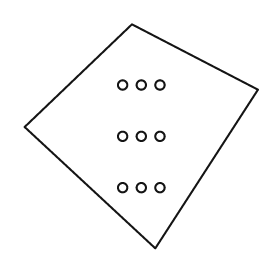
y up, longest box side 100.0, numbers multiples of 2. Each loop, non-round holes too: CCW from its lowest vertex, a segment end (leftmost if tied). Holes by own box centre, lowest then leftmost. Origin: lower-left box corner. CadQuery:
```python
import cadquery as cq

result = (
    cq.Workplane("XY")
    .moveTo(56.0, 0.0)
    .lineTo(100.0, 68.0)
    .lineTo(46.0, 96.0)
    .lineTo(0.0, 52.0)
    .close()
    .moveTo(42.0, 26.0)
    .circle(2.0)
    .moveTo(50.0, 26.0)
    .circle(2.0)
    .moveTo(58.0, 26.0)
    .circle(2.0)
    .moveTo(42.0, 48.0)
    .circle(2.0)
    .moveTo(50.0, 48.0)
    .circle(2.0)
    .moveTo(58.0, 48.0)
    .circle(2.0)
    .moveTo(42.0, 70.0)
    .circle(2.0)
    .moveTo(50.0, 70.0)
    .circle(2.0)
    .moveTo(58.0, 70.0)
    .circle(2.0)
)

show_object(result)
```